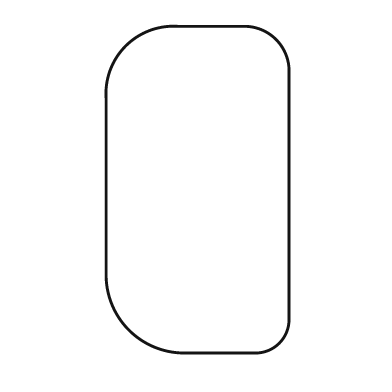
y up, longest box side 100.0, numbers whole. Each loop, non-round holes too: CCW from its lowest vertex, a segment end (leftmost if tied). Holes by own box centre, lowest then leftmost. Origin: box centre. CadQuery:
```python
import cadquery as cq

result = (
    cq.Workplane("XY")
    .moveTo(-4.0, -50.0)
    .lineTo(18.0, -50.0)
    .threePointArc((25.0, -47.0), (28.0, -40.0))
    .lineTo(28.0, 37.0)
    .threePointArc((24.0, 46.0), (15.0, 50.0))
    .lineTo(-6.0, 50.0)
    .threePointArc((-22.0, 44.0), (-28.0, 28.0))
    .lineTo(-28.0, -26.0)
    .threePointArc((-21.0, -43.0), (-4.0, -50.0))
    .close()
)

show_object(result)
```